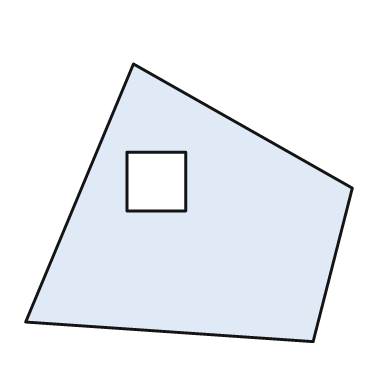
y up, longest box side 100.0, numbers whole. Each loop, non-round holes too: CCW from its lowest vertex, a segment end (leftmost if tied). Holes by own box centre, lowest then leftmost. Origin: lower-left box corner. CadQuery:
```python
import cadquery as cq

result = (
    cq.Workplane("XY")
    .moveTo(88.0, 0.0)
    .lineTo(100.0, 47.0)
    .lineTo(33.0, 85.0)
    .lineTo(0.0, 6.0)
    .close()
    .moveTo(31.0, 40.0)
    .lineTo(49.0, 40.0)
    .lineTo(49.0, 58.0)
    .lineTo(31.0, 58.0)
    .close()
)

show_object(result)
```